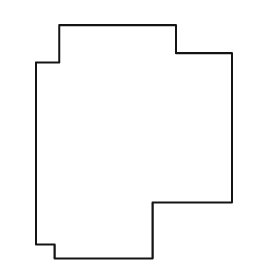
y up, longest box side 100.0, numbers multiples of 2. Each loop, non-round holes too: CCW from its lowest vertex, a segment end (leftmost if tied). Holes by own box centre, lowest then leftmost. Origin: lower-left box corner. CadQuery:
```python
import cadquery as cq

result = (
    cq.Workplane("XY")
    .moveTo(8.0, 0.0)
    .lineTo(50.0, 0.0)
    .lineTo(50.0, 24.0)
    .lineTo(84.0, 24.0)
    .lineTo(84.0, 88.0)
    .lineTo(60.0, 88.0)
    .lineTo(60.0, 100.0)
    .lineTo(10.0, 100.0)
    .lineTo(10.0, 84.0)
    .lineTo(0.0, 84.0)
    .lineTo(0.0, 6.0)
    .lineTo(8.0, 6.0)
    .close()
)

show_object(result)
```